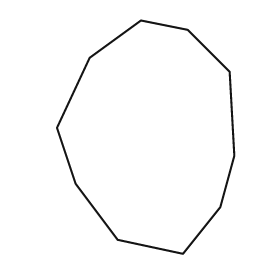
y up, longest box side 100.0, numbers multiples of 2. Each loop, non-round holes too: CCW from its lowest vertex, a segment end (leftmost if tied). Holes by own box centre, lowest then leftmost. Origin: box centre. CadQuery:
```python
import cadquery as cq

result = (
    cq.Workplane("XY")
    .moveTo(16.0, -50.0)
    .lineTo(32.0, -30.0)
    .lineTo(38.0, -8.0)
    .lineTo(36.0, 28.0)
    .lineTo(18.0, 46.0)
    .lineTo(-2.0, 50.0)
    .lineTo(-24.0, 34.0)
    .lineTo(-38.0, 4.0)
    .lineTo(-30.0, -20.0)
    .lineTo(-12.0, -44.0)
    .close()
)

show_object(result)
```